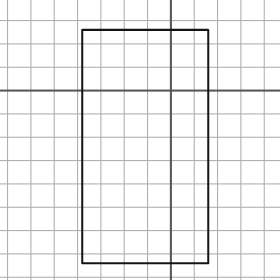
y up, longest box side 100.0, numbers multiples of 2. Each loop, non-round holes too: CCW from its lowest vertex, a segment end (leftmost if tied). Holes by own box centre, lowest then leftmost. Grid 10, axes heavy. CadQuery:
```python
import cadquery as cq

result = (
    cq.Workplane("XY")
    .moveTo(-38.0, -74.0)
    .lineTo(16.0, -74.0)
    .lineTo(16.0, 26.0)
    .lineTo(-38.0, 26.0)
    .close()
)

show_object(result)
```